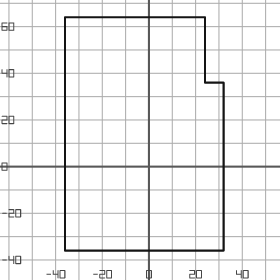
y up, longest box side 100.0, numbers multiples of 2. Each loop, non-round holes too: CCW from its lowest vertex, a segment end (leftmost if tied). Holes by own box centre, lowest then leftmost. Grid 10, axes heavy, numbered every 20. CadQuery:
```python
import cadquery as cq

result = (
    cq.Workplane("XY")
    .moveTo(-36.0, -36.0)
    .lineTo(32.0, -36.0)
    .lineTo(32.0, 36.0)
    .lineTo(24.0, 36.0)
    .lineTo(24.0, 64.0)
    .lineTo(-36.0, 64.0)
    .close()
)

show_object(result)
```